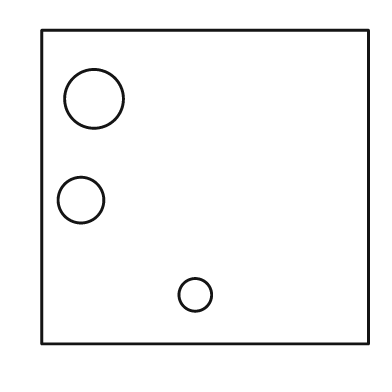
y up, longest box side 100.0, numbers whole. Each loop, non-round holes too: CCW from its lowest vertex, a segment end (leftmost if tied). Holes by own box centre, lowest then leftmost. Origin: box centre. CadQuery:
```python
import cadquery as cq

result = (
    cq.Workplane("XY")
    .moveTo(-50.0, -48.0)
    .lineTo(50.0, -48.0)
    .lineTo(50.0, 48.0)
    .lineTo(-50.0, 48.0)
    .close()
    .moveTo(-3.0, -33.0)
    .circle(5.0)
    .moveTo(-38.0, -4.0)
    .circle(7.0)
    .moveTo(-34.0, 27.0)
    .circle(9.0)
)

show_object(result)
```